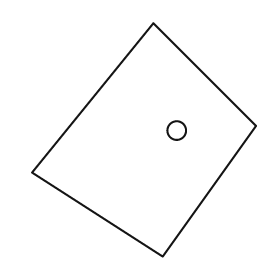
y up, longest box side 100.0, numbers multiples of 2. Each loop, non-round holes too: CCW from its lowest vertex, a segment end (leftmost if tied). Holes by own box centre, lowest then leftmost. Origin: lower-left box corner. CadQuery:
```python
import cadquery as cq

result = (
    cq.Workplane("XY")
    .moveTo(56.0, 0.0)
    .lineTo(96.0, 56.0)
    .lineTo(52.0, 100.0)
    .lineTo(0.0, 36.0)
    .close()
    .moveTo(62.0, 54.0)
    .circle(4.0)
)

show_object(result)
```